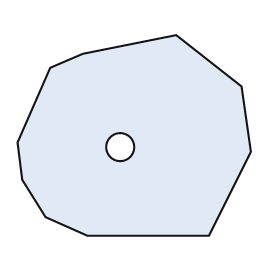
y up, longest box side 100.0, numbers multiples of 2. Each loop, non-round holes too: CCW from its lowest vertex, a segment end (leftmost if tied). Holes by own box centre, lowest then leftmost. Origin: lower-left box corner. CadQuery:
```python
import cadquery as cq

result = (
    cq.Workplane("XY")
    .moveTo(30.0, 0.0)
    .lineTo(82.0, 0.0)
    .lineTo(100.0, 36.0)
    .lineTo(96.0, 64.0)
    .lineTo(68.0, 86.0)
    .lineTo(28.0, 78.0)
    .lineTo(14.0, 72.0)
    .lineTo(0.0, 40.0)
    .lineTo(2.0, 24.0)
    .lineTo(12.0, 8.0)
    .close()
    .moveTo(44.0, 38.0)
    .circle(6.0)
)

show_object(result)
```